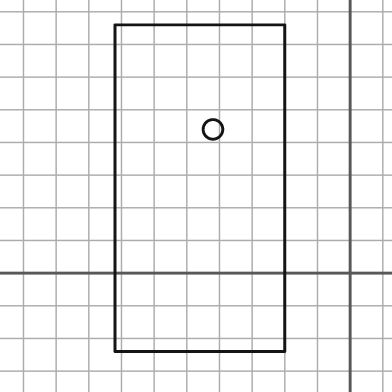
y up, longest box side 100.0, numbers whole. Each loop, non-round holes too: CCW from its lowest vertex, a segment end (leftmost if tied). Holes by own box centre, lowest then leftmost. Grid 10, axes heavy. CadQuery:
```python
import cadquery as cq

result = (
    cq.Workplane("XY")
    .moveTo(-72.0, -24.0)
    .lineTo(-20.0, -24.0)
    .lineTo(-20.0, 76.0)
    .lineTo(-72.0, 76.0)
    .close()
    .moveTo(-42.0, 44.0)
    .circle(3.0)
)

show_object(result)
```